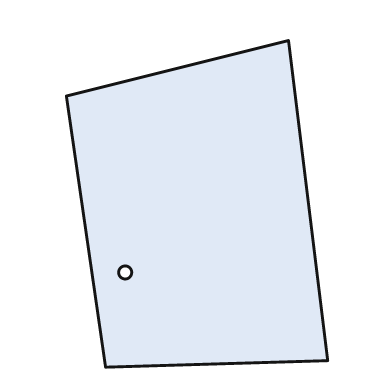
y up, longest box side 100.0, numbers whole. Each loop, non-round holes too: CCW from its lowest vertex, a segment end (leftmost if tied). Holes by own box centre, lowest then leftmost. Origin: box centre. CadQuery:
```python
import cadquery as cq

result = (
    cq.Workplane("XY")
    .moveTo(-28.0, -50.0)
    .lineTo(40.0, -48.0)
    .lineTo(28.0, 50.0)
    .lineTo(-40.0, 33.0)
    .close()
    .moveTo(-22.0, -21.0)
    .circle(2.0)
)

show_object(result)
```